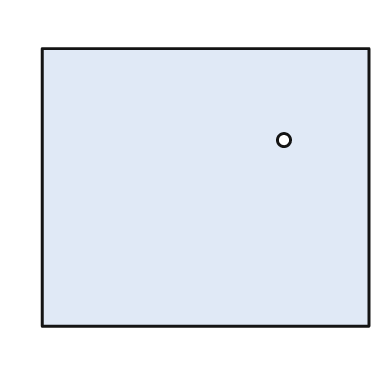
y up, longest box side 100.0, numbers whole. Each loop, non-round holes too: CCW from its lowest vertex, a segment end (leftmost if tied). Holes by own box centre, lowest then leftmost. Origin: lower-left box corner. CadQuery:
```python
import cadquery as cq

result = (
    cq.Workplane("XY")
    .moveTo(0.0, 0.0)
    .lineTo(100.0, 0.0)
    .lineTo(100.0, 85.0)
    .lineTo(0.0, 85.0)
    .close()
    .moveTo(74.0, 57.0)
    .circle(2.0)
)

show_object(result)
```